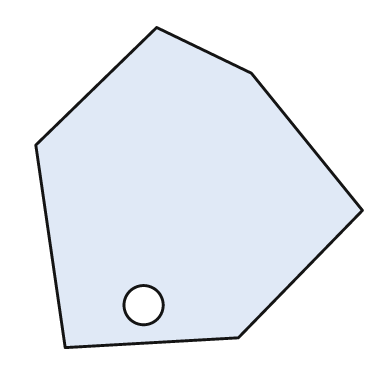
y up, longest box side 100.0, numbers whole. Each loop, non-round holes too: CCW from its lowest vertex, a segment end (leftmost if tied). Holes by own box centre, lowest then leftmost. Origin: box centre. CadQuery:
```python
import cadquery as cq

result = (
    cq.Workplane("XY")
    .moveTo(-41.0, -49.0)
    .lineTo(12.0, -46.0)
    .lineTo(50.0, -7.0)
    .lineTo(16.0, 35.0)
    .lineTo(-13.0, 49.0)
    .lineTo(-50.0, 13.0)
    .close()
    .moveTo(-17.0, -36.0)
    .circle(6.0)
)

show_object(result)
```